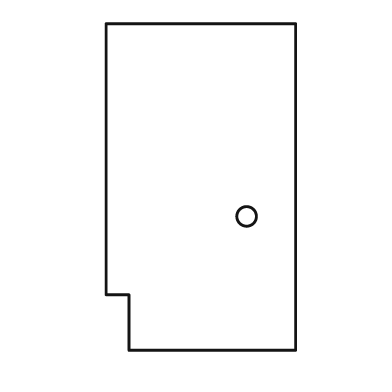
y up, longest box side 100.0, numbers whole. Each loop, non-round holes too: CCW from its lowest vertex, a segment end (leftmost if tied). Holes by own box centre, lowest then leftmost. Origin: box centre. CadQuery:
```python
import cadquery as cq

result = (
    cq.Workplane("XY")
    .moveTo(-22.0, -50.0)
    .lineTo(29.0, -50.0)
    .lineTo(29.0, 50.0)
    .lineTo(-29.0, 50.0)
    .lineTo(-29.0, -33.0)
    .lineTo(-22.0, -33.0)
    .close()
    .moveTo(14.0, -9.0)
    .circle(3.0)
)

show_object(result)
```